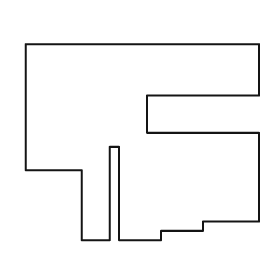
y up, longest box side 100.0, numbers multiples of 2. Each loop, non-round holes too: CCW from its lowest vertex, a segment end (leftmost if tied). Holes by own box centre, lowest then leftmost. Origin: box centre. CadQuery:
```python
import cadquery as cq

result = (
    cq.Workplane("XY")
    .moveTo(-26.0, -42.0)
    .lineTo(-14.0, -42.0)
    .lineTo(-14.0, -2.0)
    .lineTo(-10.0, -2.0)
    .lineTo(-10.0, -42.0)
    .lineTo(8.0, -42.0)
    .lineTo(8.0, -38.0)
    .lineTo(26.0, -38.0)
    .lineTo(26.0, -34.0)
    .lineTo(50.0, -34.0)
    .lineTo(50.0, 4.0)
    .lineTo(2.0, 4.0)
    .lineTo(2.0, 20.0)
    .lineTo(50.0, 20.0)
    .lineTo(50.0, 42.0)
    .lineTo(-50.0, 42.0)
    .lineTo(-50.0, -12.0)
    .lineTo(-26.0, -12.0)
    .close()
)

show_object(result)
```